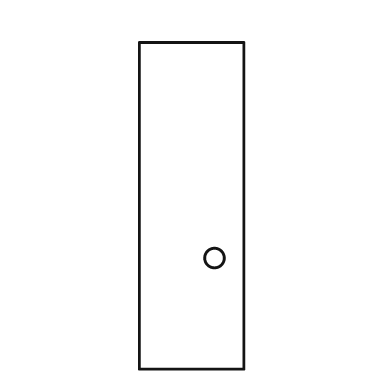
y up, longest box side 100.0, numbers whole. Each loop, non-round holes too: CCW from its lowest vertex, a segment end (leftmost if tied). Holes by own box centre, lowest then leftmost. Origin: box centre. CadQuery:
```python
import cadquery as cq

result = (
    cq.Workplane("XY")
    .moveTo(-16.0, -50.0)
    .lineTo(16.0, -50.0)
    .lineTo(16.0, 50.0)
    .lineTo(-16.0, 50.0)
    .close()
    .moveTo(7.0, -16.0)
    .circle(3.0)
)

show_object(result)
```